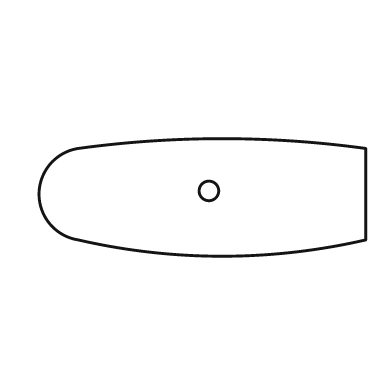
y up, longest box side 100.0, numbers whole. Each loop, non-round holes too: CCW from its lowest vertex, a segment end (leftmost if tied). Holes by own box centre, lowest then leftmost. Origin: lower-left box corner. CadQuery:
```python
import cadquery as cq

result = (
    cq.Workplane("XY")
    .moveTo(12.0, 5.0)
    .threePointArc((56.0, 0.0), (100.0, 5.0))
    .lineTo(100.0, 33.0)
    .threePointArc((56.0, 36.0), (12.0, 33.0))
    .threePointArc((0.0, 19.0), (12.0, 5.0))
    .close()
    .moveTo(52.0, 20.0)
    .circle(3.0)
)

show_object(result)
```